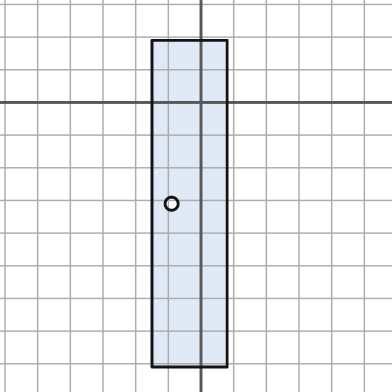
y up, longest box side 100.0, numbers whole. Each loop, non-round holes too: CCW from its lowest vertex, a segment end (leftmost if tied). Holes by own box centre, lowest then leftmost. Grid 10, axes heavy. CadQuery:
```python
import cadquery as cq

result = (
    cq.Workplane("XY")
    .moveTo(-15.0, -81.0)
    .lineTo(8.0, -81.0)
    .lineTo(8.0, 19.0)
    .lineTo(-15.0, 19.0)
    .close()
    .moveTo(-9.0, -31.0)
    .circle(2.0)
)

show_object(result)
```